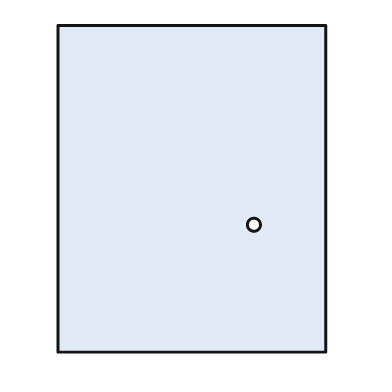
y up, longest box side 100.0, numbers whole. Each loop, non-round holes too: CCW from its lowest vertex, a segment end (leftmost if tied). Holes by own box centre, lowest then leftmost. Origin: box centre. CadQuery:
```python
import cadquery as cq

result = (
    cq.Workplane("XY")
    .moveTo(-41.0, -50.0)
    .lineTo(41.0, -50.0)
    .lineTo(41.0, 50.0)
    .lineTo(-41.0, 50.0)
    .close()
    .moveTo(19.0, -11.0)
    .circle(2.0)
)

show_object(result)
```